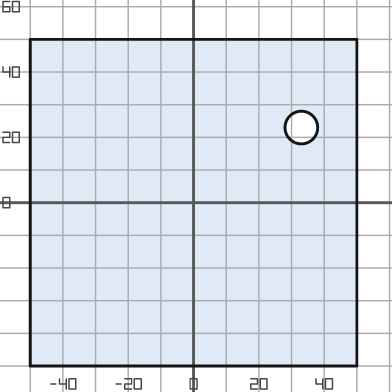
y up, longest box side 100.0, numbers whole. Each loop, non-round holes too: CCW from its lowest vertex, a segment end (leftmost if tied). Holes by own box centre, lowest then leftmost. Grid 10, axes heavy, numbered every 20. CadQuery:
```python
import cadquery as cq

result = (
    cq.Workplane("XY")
    .moveTo(-50.0, -50.0)
    .lineTo(50.0, -50.0)
    .lineTo(50.0, 50.0)
    .lineTo(-50.0, 50.0)
    .close()
    .moveTo(33.0, 23.0)
    .circle(5.0)
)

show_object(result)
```